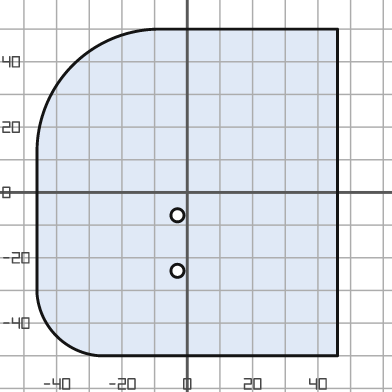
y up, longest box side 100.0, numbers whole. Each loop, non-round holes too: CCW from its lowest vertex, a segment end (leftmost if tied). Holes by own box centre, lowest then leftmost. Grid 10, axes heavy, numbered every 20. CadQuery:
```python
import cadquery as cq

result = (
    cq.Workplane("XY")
    .moveTo(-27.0, -50.0)
    .lineTo(46.0, -50.0)
    .lineTo(46.0, 50.0)
    .lineTo(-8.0, 50.0)
    .threePointArc((-35.0, 39.0), (-46.0, 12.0))
    .lineTo(-46.0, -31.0)
    .threePointArc((-40.0, -44.0), (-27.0, -50.0))
    .close()
    .moveTo(-3.0, -24.0)
    .circle(2.0)
    .moveTo(-3.0, -7.0)
    .circle(2.0)
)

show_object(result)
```